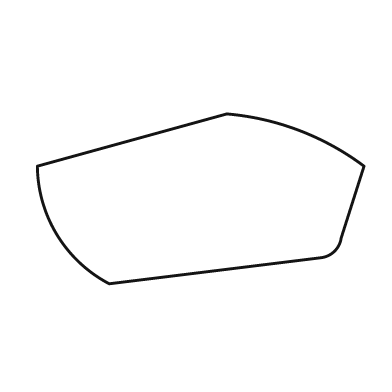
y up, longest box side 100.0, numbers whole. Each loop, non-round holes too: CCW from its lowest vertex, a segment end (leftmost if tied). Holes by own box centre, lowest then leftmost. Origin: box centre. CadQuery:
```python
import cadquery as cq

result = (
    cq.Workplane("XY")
    .moveTo(-28.0, -26.0)
    .lineTo(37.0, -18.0)
    .threePointArc((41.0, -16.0), (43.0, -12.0))
    .lineTo(50.0, 10.0)
    .threePointArc((30.0, 21.0), (8.0, 26.0))
    .lineTo(-50.0, 10.0)
    .threePointArc((-44.0, -11.0), (-28.0, -26.0))
    .close()
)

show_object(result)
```